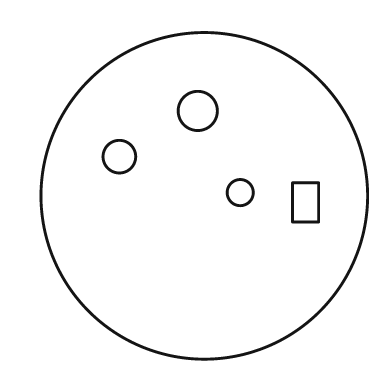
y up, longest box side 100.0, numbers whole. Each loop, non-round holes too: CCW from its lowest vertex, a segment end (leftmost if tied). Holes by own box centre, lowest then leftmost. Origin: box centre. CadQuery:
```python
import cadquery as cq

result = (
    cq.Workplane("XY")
    .moveTo(0.0, 0.0)
    .circle(50.0)
    .moveTo(27.0, -8.0)
    .lineTo(35.0, -8.0)
    .lineTo(35.0, 4.0)
    .lineTo(27.0, 4.0)
    .close()
    .moveTo(11.0, 1.0)
    .circle(4.0)
    .moveTo(-26.0, 12.0)
    .circle(5.0)
    .moveTo(-2.0, 26.0)
    .circle(6.0)
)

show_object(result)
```